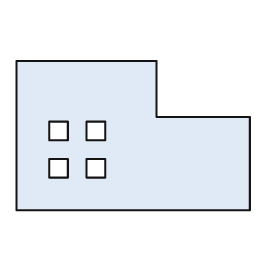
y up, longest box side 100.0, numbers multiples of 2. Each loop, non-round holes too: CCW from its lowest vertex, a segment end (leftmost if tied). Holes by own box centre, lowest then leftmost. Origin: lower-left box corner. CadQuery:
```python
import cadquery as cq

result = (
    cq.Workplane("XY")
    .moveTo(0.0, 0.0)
    .lineTo(100.0, 0.0)
    .lineTo(100.0, 40.0)
    .lineTo(60.0, 40.0)
    .lineTo(60.0, 64.0)
    .lineTo(0.0, 64.0)
    .close()
    .moveTo(14.0, 14.0)
    .lineTo(22.0, 14.0)
    .lineTo(22.0, 22.0)
    .lineTo(14.0, 22.0)
    .close()
    .moveTo(30.0, 14.0)
    .lineTo(38.0, 14.0)
    .lineTo(38.0, 22.0)
    .lineTo(30.0, 22.0)
    .close()
    .moveTo(14.0, 30.0)
    .lineTo(22.0, 30.0)
    .lineTo(22.0, 38.0)
    .lineTo(14.0, 38.0)
    .close()
    .moveTo(30.0, 30.0)
    .lineTo(38.0, 30.0)
    .lineTo(38.0, 38.0)
    .lineTo(30.0, 38.0)
    .close()
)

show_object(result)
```